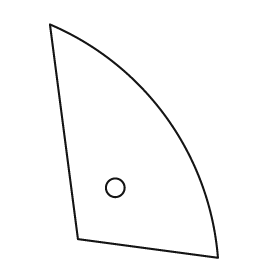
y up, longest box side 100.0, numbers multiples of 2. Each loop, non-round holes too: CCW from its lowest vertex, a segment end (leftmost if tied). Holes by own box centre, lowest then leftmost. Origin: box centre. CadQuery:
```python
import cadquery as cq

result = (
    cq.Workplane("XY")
    .moveTo(36.0, -50.0)
    .threePointArc((14.0, 10.0), (-36.0, 50.0))
    .lineTo(-24.0, -42.0)
    .close()
    .moveTo(-8.0, -20.0)
    .circle(4.0)
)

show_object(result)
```